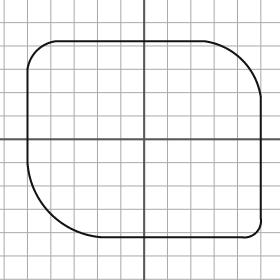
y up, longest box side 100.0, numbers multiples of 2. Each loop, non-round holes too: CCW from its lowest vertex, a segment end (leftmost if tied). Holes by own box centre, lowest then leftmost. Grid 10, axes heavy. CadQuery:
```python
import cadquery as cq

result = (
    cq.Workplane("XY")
    .moveTo(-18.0, -42.0)
    .lineTo(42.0, -42.0)
    .threePointArc((48.0, -40.0), (50.0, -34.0))
    .lineTo(50.0, 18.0)
    .threePointArc((42.0, 34.0), (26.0, 42.0))
    .lineTo(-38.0, 42.0)
    .threePointArc((-46.0, 38.0), (-50.0, 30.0))
    .lineTo(-50.0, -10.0)
    .threePointArc((-40.0, -32.0), (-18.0, -42.0))
    .close()
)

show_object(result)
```